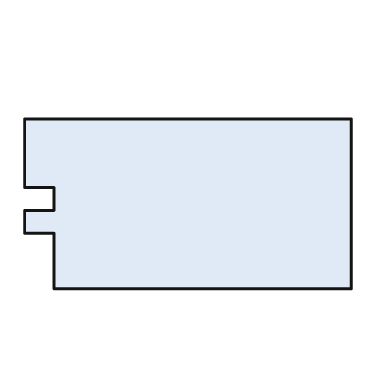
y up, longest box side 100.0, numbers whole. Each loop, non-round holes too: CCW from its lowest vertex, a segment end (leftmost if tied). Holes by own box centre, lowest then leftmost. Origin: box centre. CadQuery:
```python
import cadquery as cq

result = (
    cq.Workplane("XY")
    .moveTo(-41.0, -26.0)
    .lineTo(50.0, -26.0)
    .lineTo(50.0, 26.0)
    .lineTo(-50.0, 26.0)
    .lineTo(-50.0, 5.0)
    .lineTo(-41.0, 5.0)
    .lineTo(-41.0, -2.0)
    .lineTo(-50.0, -2.0)
    .lineTo(-50.0, -9.0)
    .lineTo(-41.0, -9.0)
    .close()
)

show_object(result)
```